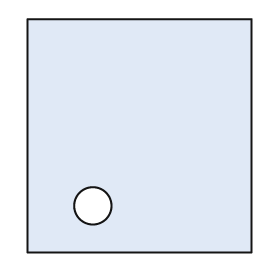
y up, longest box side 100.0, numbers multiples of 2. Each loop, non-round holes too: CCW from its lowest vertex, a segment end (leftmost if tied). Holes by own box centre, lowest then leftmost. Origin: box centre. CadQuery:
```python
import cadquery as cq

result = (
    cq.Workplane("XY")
    .moveTo(-48.0, -50.0)
    .lineTo(48.0, -50.0)
    .lineTo(48.0, 50.0)
    .lineTo(-48.0, 50.0)
    .close()
    .moveTo(-20.0, -30.0)
    .circle(8.0)
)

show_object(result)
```